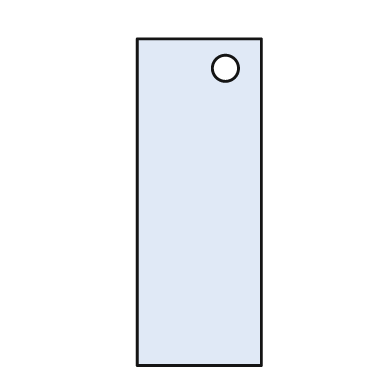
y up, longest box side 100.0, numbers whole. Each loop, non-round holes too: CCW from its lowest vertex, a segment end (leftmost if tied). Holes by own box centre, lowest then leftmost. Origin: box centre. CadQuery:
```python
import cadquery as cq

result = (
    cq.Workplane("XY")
    .moveTo(-19.0, -50.0)
    .lineTo(19.0, -50.0)
    .lineTo(19.0, 50.0)
    .lineTo(-19.0, 50.0)
    .close()
    .moveTo(8.0, 41.0)
    .circle(4.0)
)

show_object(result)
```